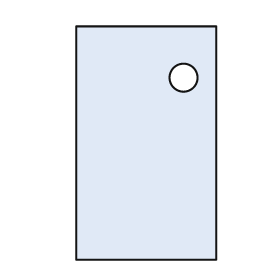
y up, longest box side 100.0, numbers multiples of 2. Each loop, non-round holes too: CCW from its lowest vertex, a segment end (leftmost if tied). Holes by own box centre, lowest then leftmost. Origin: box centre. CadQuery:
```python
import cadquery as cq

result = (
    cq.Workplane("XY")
    .moveTo(-30.0, -50.0)
    .lineTo(30.0, -50.0)
    .lineTo(30.0, 50.0)
    .lineTo(-30.0, 50.0)
    .close()
    .moveTo(16.0, 28.0)
    .circle(6.0)
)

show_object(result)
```